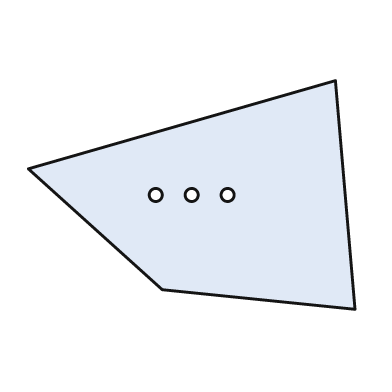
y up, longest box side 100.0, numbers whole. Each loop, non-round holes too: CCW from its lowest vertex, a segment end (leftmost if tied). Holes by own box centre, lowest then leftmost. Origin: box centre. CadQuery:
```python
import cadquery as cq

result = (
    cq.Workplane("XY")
    .moveTo(50.0, -35.0)
    .lineTo(44.0, 35.0)
    .lineTo(-50.0, 8.0)
    .lineTo(-9.0, -29.0)
    .close()
    .moveTo(-11.0, 0.0)
    .circle(2.0)
    .moveTo(0.0, 0.0)
    .circle(2.0)
    .moveTo(11.0, 0.0)
    .circle(2.0)
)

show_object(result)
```